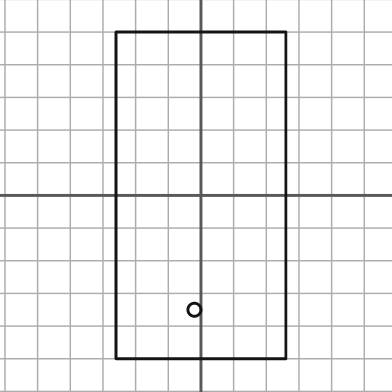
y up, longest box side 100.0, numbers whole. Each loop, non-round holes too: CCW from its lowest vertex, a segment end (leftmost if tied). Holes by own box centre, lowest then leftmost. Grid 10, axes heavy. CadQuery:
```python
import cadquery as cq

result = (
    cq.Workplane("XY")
    .moveTo(-26.0, -50.0)
    .lineTo(26.0, -50.0)
    .lineTo(26.0, 50.0)
    .lineTo(-26.0, 50.0)
    .close()
    .moveTo(-2.0, -35.0)
    .circle(2.0)
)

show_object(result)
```